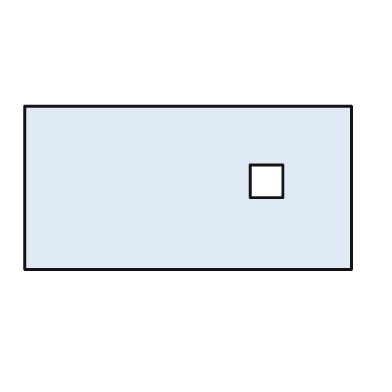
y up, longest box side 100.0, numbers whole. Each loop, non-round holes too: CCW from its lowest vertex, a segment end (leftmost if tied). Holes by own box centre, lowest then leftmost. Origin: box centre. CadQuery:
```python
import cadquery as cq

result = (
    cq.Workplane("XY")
    .moveTo(-50.0, -25.0)
    .lineTo(50.0, -25.0)
    .lineTo(50.0, 25.0)
    .lineTo(-50.0, 25.0)
    .close()
    .moveTo(19.0, -3.0)
    .lineTo(29.0, -3.0)
    .lineTo(29.0, 7.0)
    .lineTo(19.0, 7.0)
    .close()
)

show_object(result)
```